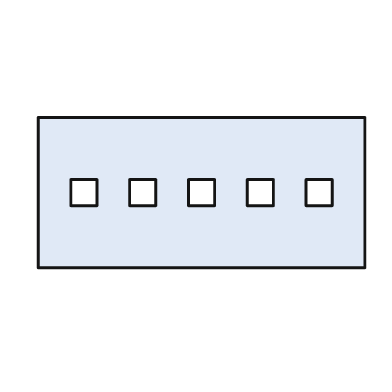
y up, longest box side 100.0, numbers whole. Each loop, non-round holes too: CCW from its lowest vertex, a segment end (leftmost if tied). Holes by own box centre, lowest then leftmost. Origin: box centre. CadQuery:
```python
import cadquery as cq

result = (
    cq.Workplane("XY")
    .moveTo(-50.0, -23.0)
    .lineTo(50.0, -23.0)
    .lineTo(50.0, 23.0)
    .lineTo(-50.0, 23.0)
    .close()
    .moveTo(-40.0, -4.0)
    .lineTo(-32.0, -4.0)
    .lineTo(-32.0, 4.0)
    .lineTo(-40.0, 4.0)
    .close()
    .moveTo(-22.0, -4.0)
    .lineTo(-14.0, -4.0)
    .lineTo(-14.0, 4.0)
    .lineTo(-22.0, 4.0)
    .close()
    .moveTo(-4.0, -4.0)
    .lineTo(4.0, -4.0)
    .lineTo(4.0, 4.0)
    .lineTo(-4.0, 4.0)
    .close()
    .moveTo(14.0, -4.0)
    .lineTo(22.0, -4.0)
    .lineTo(22.0, 4.0)
    .lineTo(14.0, 4.0)
    .close()
    .moveTo(32.0, -4.0)
    .lineTo(40.0, -4.0)
    .lineTo(40.0, 4.0)
    .lineTo(32.0, 4.0)
    .close()
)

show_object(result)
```